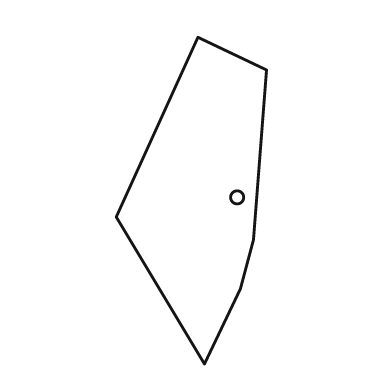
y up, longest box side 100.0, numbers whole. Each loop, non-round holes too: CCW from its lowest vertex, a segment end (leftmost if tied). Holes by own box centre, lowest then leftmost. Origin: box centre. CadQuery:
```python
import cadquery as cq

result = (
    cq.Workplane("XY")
    .moveTo(4.0, -50.0)
    .lineTo(15.0, -27.0)
    .lineTo(19.0, -12.0)
    .lineTo(23.0, 40.0)
    .lineTo(2.0, 50.0)
    .lineTo(-23.0, -5.0)
    .close()
    .moveTo(14.0, 1.0)
    .circle(2.0)
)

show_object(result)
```